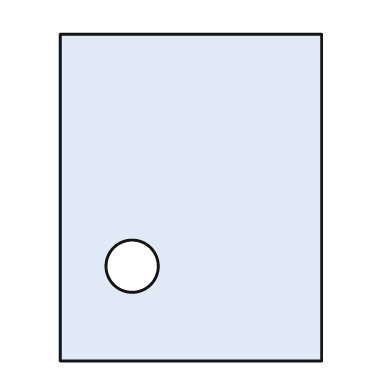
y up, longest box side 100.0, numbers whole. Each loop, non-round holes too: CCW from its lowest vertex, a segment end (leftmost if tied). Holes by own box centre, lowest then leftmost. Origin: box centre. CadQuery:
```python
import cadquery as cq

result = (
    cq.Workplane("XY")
    .moveTo(-40.0, -50.0)
    .lineTo(40.0, -50.0)
    .lineTo(40.0, 50.0)
    .lineTo(-40.0, 50.0)
    .close()
    .moveTo(-18.0, -21.0)
    .circle(8.0)
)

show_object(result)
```